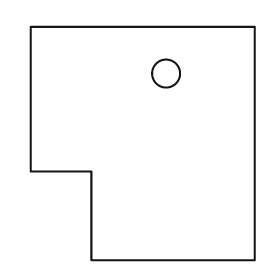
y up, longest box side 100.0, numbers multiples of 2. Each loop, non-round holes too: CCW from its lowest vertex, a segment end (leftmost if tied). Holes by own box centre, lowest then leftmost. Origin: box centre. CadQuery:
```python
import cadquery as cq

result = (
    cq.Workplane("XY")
    .moveTo(-22.0, -50.0)
    .lineTo(48.0, -50.0)
    .lineTo(48.0, 50.0)
    .lineTo(-48.0, 50.0)
    .lineTo(-48.0, -12.0)
    .lineTo(-22.0, -12.0)
    .close()
    .moveTo(10.0, 30.0)
    .circle(6.0)
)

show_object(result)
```